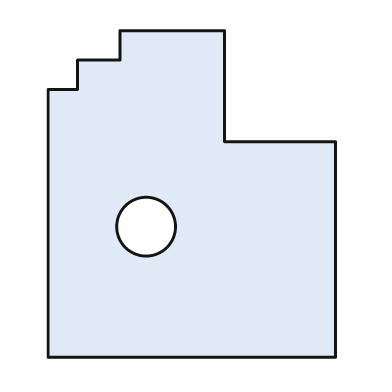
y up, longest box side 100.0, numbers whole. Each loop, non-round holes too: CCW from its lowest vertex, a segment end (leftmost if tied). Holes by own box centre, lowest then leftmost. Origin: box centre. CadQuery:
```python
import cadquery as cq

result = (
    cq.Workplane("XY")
    .moveTo(-44.0, -50.0)
    .lineTo(44.0, -50.0)
    .lineTo(44.0, 16.0)
    .lineTo(10.0, 16.0)
    .lineTo(10.0, 50.0)
    .lineTo(-22.0, 50.0)
    .lineTo(-22.0, 41.0)
    .lineTo(-35.0, 41.0)
    .lineTo(-35.0, 32.0)
    .lineTo(-44.0, 32.0)
    .close()
    .moveTo(-14.0, -10.0)
    .circle(9.0)
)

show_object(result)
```